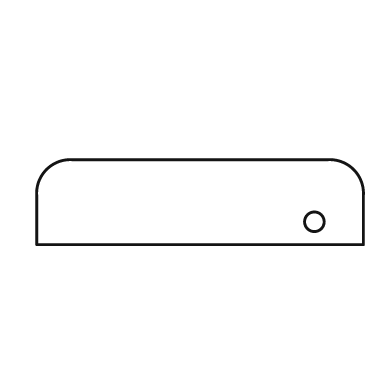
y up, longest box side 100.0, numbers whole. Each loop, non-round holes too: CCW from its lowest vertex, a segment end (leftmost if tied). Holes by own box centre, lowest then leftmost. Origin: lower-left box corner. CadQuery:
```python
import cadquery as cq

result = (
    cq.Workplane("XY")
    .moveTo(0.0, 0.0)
    .lineTo(100.0, 0.0)
    .lineTo(100.0, 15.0)
    .threePointArc((97.0, 23.0), (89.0, 26.0))
    .lineTo(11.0, 26.0)
    .threePointArc((3.0, 23.0), (0.0, 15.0))
    .close()
    .moveTo(85.0, 7.0)
    .circle(3.0)
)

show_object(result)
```